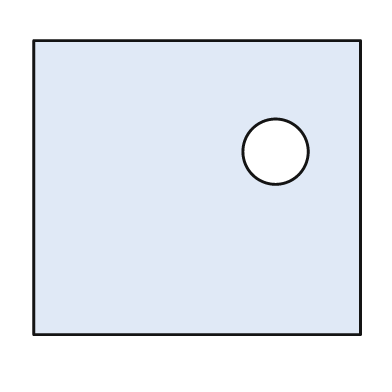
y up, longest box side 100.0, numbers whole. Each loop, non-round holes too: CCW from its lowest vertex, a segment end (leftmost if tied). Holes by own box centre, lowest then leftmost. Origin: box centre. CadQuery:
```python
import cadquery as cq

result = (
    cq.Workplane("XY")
    .moveTo(-50.0, -45.0)
    .lineTo(50.0, -45.0)
    .lineTo(50.0, 45.0)
    .lineTo(-50.0, 45.0)
    .close()
    .moveTo(24.0, 11.0)
    .circle(10.0)
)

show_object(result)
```